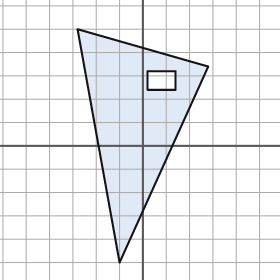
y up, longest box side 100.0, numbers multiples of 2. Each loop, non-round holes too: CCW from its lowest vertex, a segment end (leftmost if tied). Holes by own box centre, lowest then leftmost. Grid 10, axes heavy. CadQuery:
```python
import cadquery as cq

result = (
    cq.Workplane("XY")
    .moveTo(-10.0, -50.0)
    .lineTo(28.0, 34.0)
    .lineTo(-28.0, 50.0)
    .close()
    .moveTo(2.0, 24.0)
    .lineTo(14.0, 24.0)
    .lineTo(14.0, 32.0)
    .lineTo(2.0, 32.0)
    .close()
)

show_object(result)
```